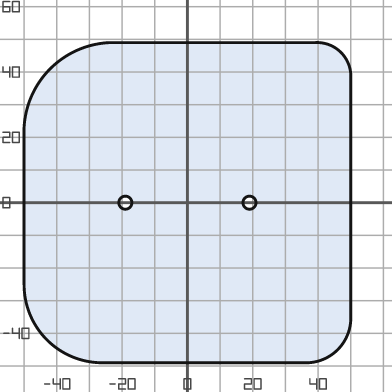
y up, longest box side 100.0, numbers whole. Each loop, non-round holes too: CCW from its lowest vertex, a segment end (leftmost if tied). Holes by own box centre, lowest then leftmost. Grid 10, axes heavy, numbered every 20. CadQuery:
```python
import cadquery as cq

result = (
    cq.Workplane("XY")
    .moveTo(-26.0, -49.0)
    .lineTo(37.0, -49.0)
    .threePointArc((46.0, -45.0), (50.0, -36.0))
    .lineTo(50.0, 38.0)
    .threePointArc((47.0, 46.0), (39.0, 49.0))
    .lineTo(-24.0, 49.0)
    .threePointArc((-42.0, 41.0), (-50.0, 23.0))
    .lineTo(-50.0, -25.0)
    .threePointArc((-43.0, -42.0), (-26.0, -49.0))
    .close()
    .moveTo(-19.0, 0.0)
    .circle(2.0)
    .moveTo(19.0, 0.0)
    .circle(2.0)
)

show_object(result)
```